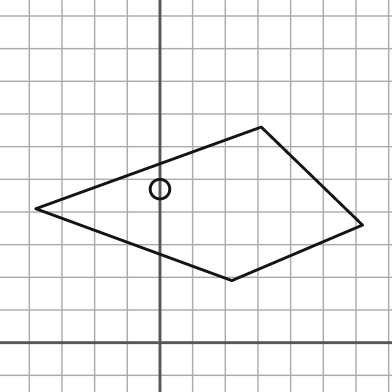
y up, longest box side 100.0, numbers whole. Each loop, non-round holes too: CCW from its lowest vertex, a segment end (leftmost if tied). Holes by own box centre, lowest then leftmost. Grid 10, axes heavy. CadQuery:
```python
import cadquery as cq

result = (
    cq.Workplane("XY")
    .moveTo(22.0, 19.0)
    .lineTo(62.0, 36.0)
    .lineTo(31.0, 66.0)
    .lineTo(-38.0, 41.0)
    .close()
    .moveTo(0.0, 47.0)
    .circle(3.0)
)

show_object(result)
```